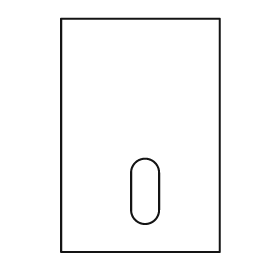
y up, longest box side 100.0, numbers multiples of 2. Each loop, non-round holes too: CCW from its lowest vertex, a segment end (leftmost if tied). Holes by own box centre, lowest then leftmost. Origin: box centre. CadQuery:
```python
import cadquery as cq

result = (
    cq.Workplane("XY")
    .moveTo(-34.0, -50.0)
    .lineTo(34.0, -50.0)
    .lineTo(34.0, 50.0)
    .lineTo(-34.0, 50.0)
    .close()
    .moveTo(-4.0, -32.0)
    .threePointArc((2.0, -38.0), (8.0, -32.0))
    .lineTo(8.0, -16.0)
    .threePointArc((2.0, -10.0), (-4.0, -16.0))
    .close()
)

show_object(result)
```